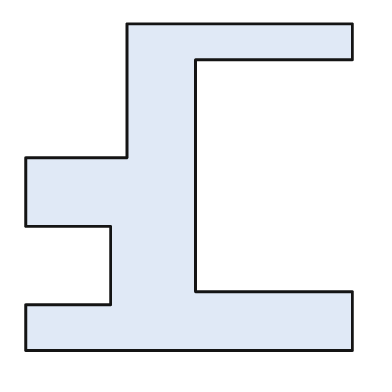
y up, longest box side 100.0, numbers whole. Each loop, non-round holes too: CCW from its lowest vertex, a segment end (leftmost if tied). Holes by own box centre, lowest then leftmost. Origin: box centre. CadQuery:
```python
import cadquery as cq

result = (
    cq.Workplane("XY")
    .moveTo(-50.0, -50.0)
    .lineTo(50.0, -50.0)
    .lineTo(50.0, -32.0)
    .lineTo(2.0, -32.0)
    .lineTo(2.0, 39.0)
    .lineTo(50.0, 39.0)
    .lineTo(50.0, 50.0)
    .lineTo(-19.0, 50.0)
    .lineTo(-19.0, 9.0)
    .lineTo(-50.0, 9.0)
    .lineTo(-50.0, -12.0)
    .lineTo(-24.0, -12.0)
    .lineTo(-24.0, -36.0)
    .lineTo(-50.0, -36.0)
    .close()
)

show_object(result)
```